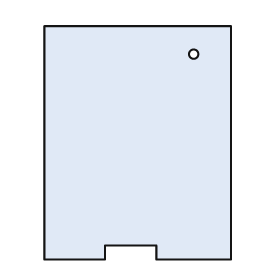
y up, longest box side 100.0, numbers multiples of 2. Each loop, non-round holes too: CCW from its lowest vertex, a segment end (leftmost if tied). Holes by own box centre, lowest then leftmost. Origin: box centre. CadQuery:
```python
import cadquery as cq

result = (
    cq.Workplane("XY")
    .moveTo(-40.0, -50.0)
    .lineTo(-14.0, -50.0)
    .lineTo(-14.0, -44.0)
    .lineTo(8.0, -44.0)
    .lineTo(8.0, -50.0)
    .lineTo(40.0, -50.0)
    .lineTo(40.0, 50.0)
    .lineTo(-40.0, 50.0)
    .close()
    .moveTo(24.0, 38.0)
    .circle(2.0)
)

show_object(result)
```